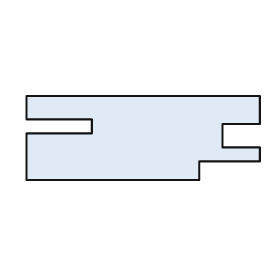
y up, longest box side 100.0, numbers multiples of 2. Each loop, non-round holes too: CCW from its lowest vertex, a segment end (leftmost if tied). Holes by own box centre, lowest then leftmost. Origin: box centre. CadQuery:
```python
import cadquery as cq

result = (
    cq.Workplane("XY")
    .moveTo(-50.0, -18.0)
    .lineTo(24.0, -18.0)
    .lineTo(24.0, -10.0)
    .lineTo(50.0, -10.0)
    .lineTo(50.0, -4.0)
    .lineTo(34.0, -4.0)
    .lineTo(34.0, 6.0)
    .lineTo(50.0, 6.0)
    .lineTo(50.0, 18.0)
    .lineTo(-50.0, 18.0)
    .lineTo(-50.0, 8.0)
    .lineTo(-22.0, 8.0)
    .lineTo(-22.0, 2.0)
    .lineTo(-50.0, 2.0)
    .close()
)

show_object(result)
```